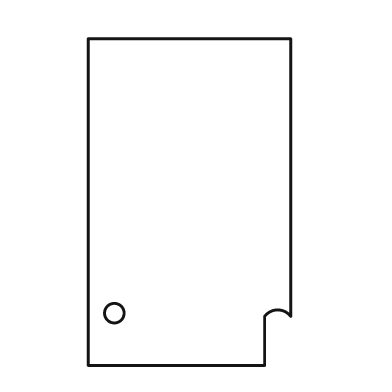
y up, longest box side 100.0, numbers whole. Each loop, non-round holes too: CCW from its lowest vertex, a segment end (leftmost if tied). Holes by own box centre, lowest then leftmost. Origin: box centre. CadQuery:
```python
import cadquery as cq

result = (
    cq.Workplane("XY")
    .moveTo(-31.0, -50.0)
    .lineTo(23.0, -50.0)
    .lineTo(23.0, -35.0)
    .threePointArc((27.0, -33.0), (31.0, -35.0))
    .lineTo(31.0, 50.0)
    .lineTo(-31.0, 50.0)
    .close()
    .moveTo(-23.0, -34.0)
    .circle(3.0)
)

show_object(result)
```